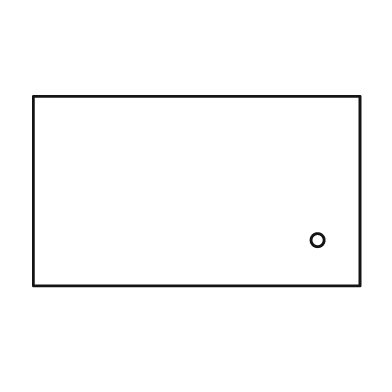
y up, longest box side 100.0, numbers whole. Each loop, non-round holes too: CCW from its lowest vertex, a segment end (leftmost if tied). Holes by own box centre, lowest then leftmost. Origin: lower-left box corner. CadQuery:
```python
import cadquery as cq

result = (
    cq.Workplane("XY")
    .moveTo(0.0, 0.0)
    .lineTo(100.0, 0.0)
    .lineTo(100.0, 58.0)
    .lineTo(0.0, 58.0)
    .close()
    .moveTo(87.0, 14.0)
    .circle(2.0)
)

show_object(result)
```